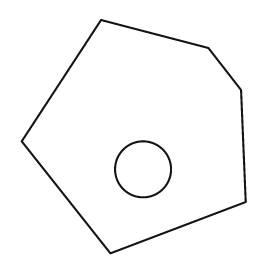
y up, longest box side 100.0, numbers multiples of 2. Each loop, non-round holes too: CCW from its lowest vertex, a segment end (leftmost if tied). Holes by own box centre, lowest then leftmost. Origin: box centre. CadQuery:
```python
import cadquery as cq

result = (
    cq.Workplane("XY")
    .moveTo(-10.0, -50.0)
    .lineTo(48.0, -28.0)
    .lineTo(46.0, 20.0)
    .lineTo(32.0, 38.0)
    .lineTo(-14.0, 50.0)
    .lineTo(-48.0, -2.0)
    .close()
    .moveTo(4.0, -14.0)
    .circle(12.0)
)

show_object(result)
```